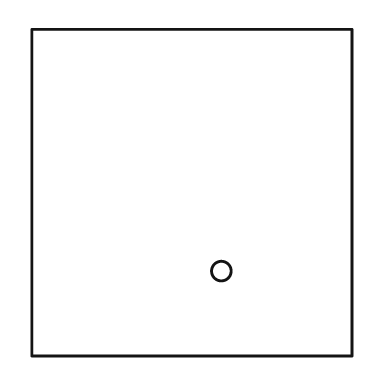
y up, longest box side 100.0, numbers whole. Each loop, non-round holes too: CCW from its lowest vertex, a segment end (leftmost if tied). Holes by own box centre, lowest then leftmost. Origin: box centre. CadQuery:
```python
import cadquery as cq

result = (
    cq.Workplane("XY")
    .moveTo(-49.0, -50.0)
    .lineTo(49.0, -50.0)
    .lineTo(49.0, 50.0)
    .lineTo(-49.0, 50.0)
    .close()
    .moveTo(9.0, -24.0)
    .circle(3.0)
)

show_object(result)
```